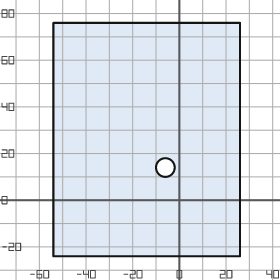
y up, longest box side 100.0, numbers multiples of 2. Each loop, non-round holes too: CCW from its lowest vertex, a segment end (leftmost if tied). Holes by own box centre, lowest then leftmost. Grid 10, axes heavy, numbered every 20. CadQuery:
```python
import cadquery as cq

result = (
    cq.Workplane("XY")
    .moveTo(-54.0, -24.0)
    .lineTo(26.0, -24.0)
    .lineTo(26.0, 76.0)
    .lineTo(-54.0, 76.0)
    .close()
    .moveTo(-6.0, 14.0)
    .circle(4.0)
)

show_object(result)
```